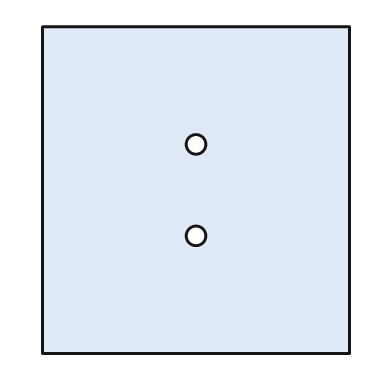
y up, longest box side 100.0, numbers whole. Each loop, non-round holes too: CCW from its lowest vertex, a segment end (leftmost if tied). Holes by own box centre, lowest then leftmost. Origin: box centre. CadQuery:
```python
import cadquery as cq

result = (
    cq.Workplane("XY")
    .moveTo(-47.0, -50.0)
    .lineTo(47.0, -50.0)
    .lineTo(47.0, 50.0)
    .lineTo(-47.0, 50.0)
    .close()
    .moveTo(0.0, -14.0)
    .circle(3.0)
    .moveTo(0.0, 14.0)
    .circle(3.0)
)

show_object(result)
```